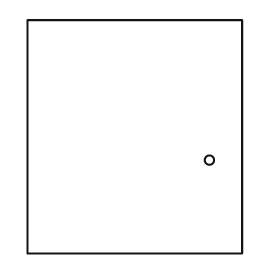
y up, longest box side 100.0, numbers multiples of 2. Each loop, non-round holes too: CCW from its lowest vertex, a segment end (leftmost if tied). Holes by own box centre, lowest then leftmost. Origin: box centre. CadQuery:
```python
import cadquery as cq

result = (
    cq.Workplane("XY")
    .moveTo(-46.0, -50.0)
    .lineTo(46.0, -50.0)
    .lineTo(46.0, 50.0)
    .lineTo(-46.0, 50.0)
    .close()
    .moveTo(32.0, -10.0)
    .circle(2.0)
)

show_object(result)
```